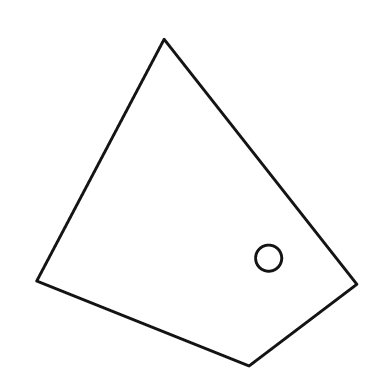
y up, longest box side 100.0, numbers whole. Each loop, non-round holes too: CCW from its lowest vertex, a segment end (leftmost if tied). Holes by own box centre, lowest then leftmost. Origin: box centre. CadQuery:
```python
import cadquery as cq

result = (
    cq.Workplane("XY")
    .moveTo(16.0, -50.0)
    .lineTo(49.0, -25.0)
    .lineTo(-10.0, 50.0)
    .lineTo(-49.0, -24.0)
    .close()
    .moveTo(22.0, -17.0)
    .circle(4.0)
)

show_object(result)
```